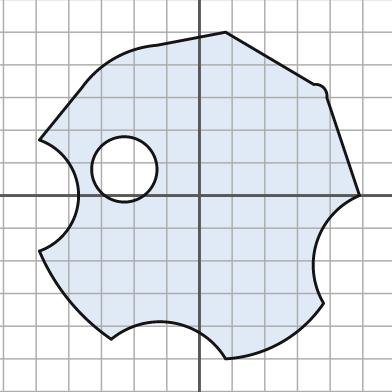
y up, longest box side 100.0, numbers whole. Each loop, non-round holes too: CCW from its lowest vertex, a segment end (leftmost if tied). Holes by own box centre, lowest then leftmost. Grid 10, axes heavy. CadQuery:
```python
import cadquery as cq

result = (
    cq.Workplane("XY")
    .moveTo(8.0, -50.0)
    .threePointArc((25.0, -45.0), (38.0, -33.0))
    .threePointArc((36.0, -14.0), (49.0, 0.0))
    .lineTo(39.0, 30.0)
    .threePointArc((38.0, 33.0), (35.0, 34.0))
    .lineTo(8.0, 50.0)
    .lineTo(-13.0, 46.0)
    .threePointArc((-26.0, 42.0), (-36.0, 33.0))
    .lineTo(-49.0, 17.0)
    .threePointArc((-37.0, 0.0), (-49.0, -17.0))
    .threePointArc((-40.0, -32.0), (-27.0, -44.0))
    .threePointArc((-8.0, -39.0), (8.0, -50.0))
    .close()
    .moveTo(-23.0, 8.0)
    .circle(10.0)
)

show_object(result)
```